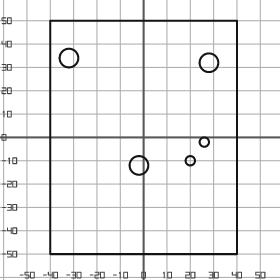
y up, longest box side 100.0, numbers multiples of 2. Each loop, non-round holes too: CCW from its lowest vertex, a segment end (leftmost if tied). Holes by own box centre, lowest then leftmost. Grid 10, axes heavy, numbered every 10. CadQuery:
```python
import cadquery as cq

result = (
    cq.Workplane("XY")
    .moveTo(-40.0, -50.0)
    .lineTo(40.0, -50.0)
    .lineTo(40.0, 50.0)
    .lineTo(-40.0, 50.0)
    .close()
    .moveTo(-2.0, -12.0)
    .circle(4.0)
    .moveTo(20.0, -10.0)
    .circle(2.0)
    .moveTo(26.0, -2.0)
    .circle(2.0)
    .moveTo(28.0, 32.0)
    .circle(4.0)
    .moveTo(-32.0, 34.0)
    .circle(4.0)
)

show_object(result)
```